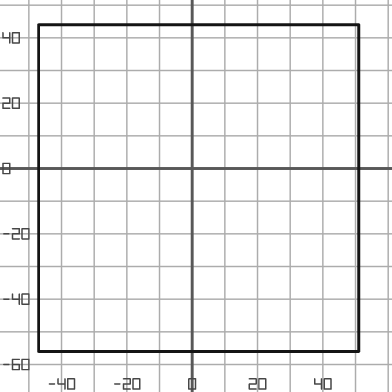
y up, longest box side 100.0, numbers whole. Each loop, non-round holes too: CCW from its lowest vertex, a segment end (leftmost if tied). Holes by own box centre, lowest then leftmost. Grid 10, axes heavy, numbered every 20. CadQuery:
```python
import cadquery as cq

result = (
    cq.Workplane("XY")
    .moveTo(-47.0, -56.0)
    .lineTo(51.0, -56.0)
    .lineTo(51.0, 44.0)
    .lineTo(-47.0, 44.0)
    .close()
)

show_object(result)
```